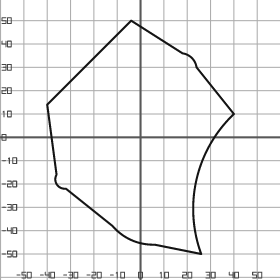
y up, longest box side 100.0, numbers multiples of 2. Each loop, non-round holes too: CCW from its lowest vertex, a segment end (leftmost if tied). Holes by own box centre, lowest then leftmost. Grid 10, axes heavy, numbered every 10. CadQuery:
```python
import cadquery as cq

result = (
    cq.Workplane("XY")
    .moveTo(26.0, -50.0)
    .threePointArc((24.0, -18.0), (40.0, 10.0))
    .lineTo(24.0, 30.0)
    .threePointArc((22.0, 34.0), (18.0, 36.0))
    .lineTo(-4.0, 50.0)
    .lineTo(-40.0, 14.0)
    .lineTo(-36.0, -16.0)
    .threePointArc((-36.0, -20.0), (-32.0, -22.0))
    .lineTo(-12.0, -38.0)
    .threePointArc((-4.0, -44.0), (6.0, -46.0))
    .close()
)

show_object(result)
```